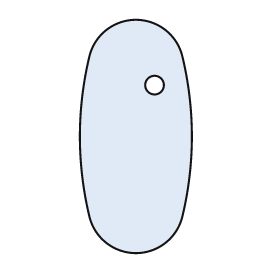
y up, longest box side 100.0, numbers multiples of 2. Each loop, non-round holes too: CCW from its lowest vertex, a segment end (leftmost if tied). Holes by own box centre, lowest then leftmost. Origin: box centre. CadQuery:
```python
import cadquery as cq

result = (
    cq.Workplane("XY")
    .moveTo(-20.0, -34.0)
    .threePointArc((0.0, -50.0), (20.0, -34.0))
    .threePointArc((24.0, 0.0), (20.0, 34.0))
    .threePointArc((0.0, 50.0), (-20.0, 34.0))
    .threePointArc((-24.0, 0.0), (-20.0, -34.0))
    .close()
    .moveTo(8.0, 22.0)
    .circle(4.0)
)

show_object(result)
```